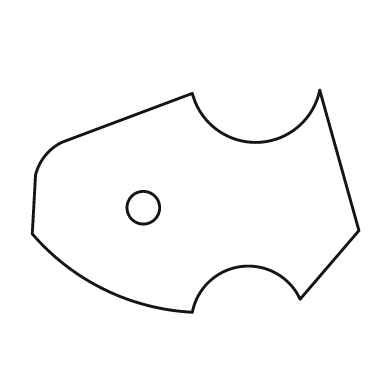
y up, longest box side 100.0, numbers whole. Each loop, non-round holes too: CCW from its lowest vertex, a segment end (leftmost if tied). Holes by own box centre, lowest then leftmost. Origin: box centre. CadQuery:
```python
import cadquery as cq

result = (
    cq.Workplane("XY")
    .moveTo(-1.0, -34.0)
    .threePointArc((14.0, -20.0), (32.0, -30.0))
    .lineTo(50.0, -9.0)
    .lineTo(38.0, 34.0)
    .threePointArc((19.0, 18.0), (-1.0, 33.0))
    .lineTo(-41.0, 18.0)
    .threePointArc((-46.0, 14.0), (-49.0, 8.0))
    .lineTo(-50.0, -10.0)
    .threePointArc((-28.0, -27.0), (-1.0, -34.0))
    .close()
    .moveTo(-16.0, -2.0)
    .circle(5.0)
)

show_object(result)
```